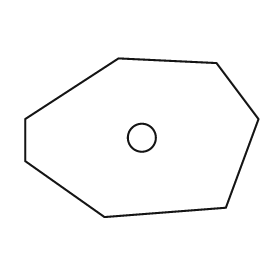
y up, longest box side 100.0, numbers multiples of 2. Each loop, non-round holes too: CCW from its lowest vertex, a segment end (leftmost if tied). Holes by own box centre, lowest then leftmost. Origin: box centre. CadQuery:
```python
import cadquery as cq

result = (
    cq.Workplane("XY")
    .moveTo(-16.0, -34.0)
    .lineTo(36.0, -30.0)
    .lineTo(50.0, 8.0)
    .lineTo(32.0, 32.0)
    .lineTo(-10.0, 34.0)
    .lineTo(-50.0, 8.0)
    .lineTo(-50.0, -10.0)
    .close()
    .moveTo(0.0, 0.0)
    .circle(6.0)
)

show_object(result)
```